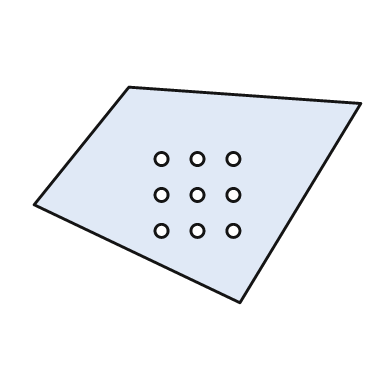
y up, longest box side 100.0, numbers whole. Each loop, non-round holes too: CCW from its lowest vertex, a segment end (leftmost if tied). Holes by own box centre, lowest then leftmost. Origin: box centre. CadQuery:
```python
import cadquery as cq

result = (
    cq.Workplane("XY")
    .moveTo(13.0, -33.0)
    .lineTo(50.0, 28.0)
    .lineTo(-21.0, 33.0)
    .lineTo(-50.0, -3.0)
    .close()
    .moveTo(-11.0, -11.0)
    .circle(2.0)
    .moveTo(0.0, -11.0)
    .circle(2.0)
    .moveTo(11.0, -11.0)
    .circle(2.0)
    .moveTo(-11.0, 0.0)
    .circle(2.0)
    .moveTo(0.0, 0.0)
    .circle(2.0)
    .moveTo(11.0, 0.0)
    .circle(2.0)
    .moveTo(-11.0, 11.0)
    .circle(2.0)
    .moveTo(0.0, 11.0)
    .circle(2.0)
    .moveTo(11.0, 11.0)
    .circle(2.0)
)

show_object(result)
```